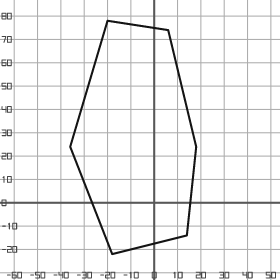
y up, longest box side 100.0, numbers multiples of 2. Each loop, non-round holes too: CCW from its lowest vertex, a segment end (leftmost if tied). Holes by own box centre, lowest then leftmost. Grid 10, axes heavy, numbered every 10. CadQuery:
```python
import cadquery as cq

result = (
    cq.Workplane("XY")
    .moveTo(-18.0, -22.0)
    .lineTo(14.0, -14.0)
    .lineTo(18.0, 24.0)
    .lineTo(6.0, 74.0)
    .lineTo(-20.0, 78.0)
    .lineTo(-36.0, 24.0)
    .close()
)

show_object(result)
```